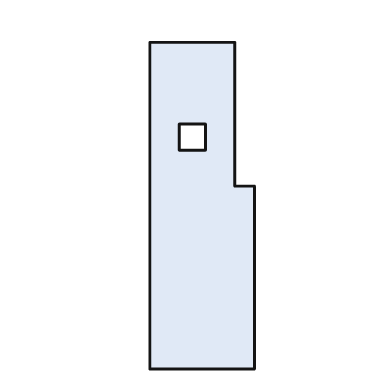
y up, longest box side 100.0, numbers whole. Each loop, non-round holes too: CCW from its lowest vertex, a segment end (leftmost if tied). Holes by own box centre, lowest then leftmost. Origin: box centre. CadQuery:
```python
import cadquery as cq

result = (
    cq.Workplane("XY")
    .moveTo(-16.0, -50.0)
    .lineTo(16.0, -50.0)
    .lineTo(16.0, 6.0)
    .lineTo(10.0, 6.0)
    .lineTo(10.0, 50.0)
    .lineTo(-16.0, 50.0)
    .close()
    .moveTo(-7.0, 17.0)
    .lineTo(1.0, 17.0)
    .lineTo(1.0, 25.0)
    .lineTo(-7.0, 25.0)
    .close()
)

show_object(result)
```